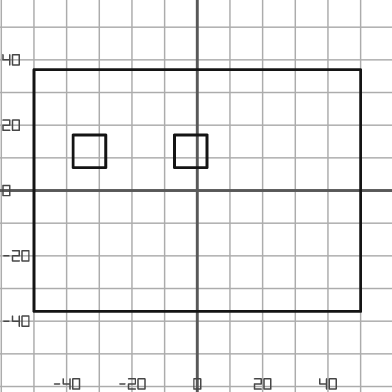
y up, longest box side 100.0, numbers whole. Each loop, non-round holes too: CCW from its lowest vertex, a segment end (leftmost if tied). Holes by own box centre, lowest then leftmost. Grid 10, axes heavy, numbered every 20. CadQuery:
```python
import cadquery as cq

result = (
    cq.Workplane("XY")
    .moveTo(-50.0, -37.0)
    .lineTo(50.0, -37.0)
    .lineTo(50.0, 37.0)
    .lineTo(-50.0, 37.0)
    .close()
    .moveTo(-38.0, 7.0)
    .lineTo(-28.0, 7.0)
    .lineTo(-28.0, 17.0)
    .lineTo(-38.0, 17.0)
    .close()
    .moveTo(-7.0, 7.0)
    .lineTo(3.0, 7.0)
    .lineTo(3.0, 17.0)
    .lineTo(-7.0, 17.0)
    .close()
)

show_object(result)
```